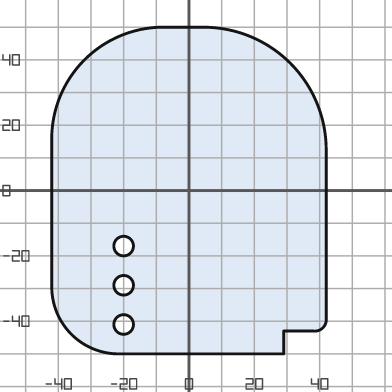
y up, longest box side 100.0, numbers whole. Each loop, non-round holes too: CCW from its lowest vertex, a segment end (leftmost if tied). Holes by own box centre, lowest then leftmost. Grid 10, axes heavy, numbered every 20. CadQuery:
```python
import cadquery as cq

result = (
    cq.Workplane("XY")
    .moveTo(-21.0, -50.0)
    .lineTo(29.0, -50.0)
    .lineTo(29.0, -43.0)
    .lineTo(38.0, -43.0)
    .threePointArc((41.0, -42.0), (42.0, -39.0))
    .lineTo(42.0, 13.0)
    .threePointArc((31.0, 39.0), (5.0, 50.0))
    .lineTo(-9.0, 50.0)
    .threePointArc((-32.0, 40.0), (-42.0, 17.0))
    .lineTo(-42.0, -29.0)
    .threePointArc((-36.0, -44.0), (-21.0, -50.0))
    .close()
    .moveTo(-20.0, -41.0)
    .circle(3.0)
    .moveTo(-20.0, -29.0)
    .circle(3.0)
    .moveTo(-20.0, -17.0)
    .circle(3.0)
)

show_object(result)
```